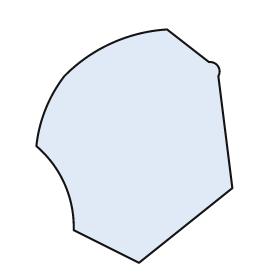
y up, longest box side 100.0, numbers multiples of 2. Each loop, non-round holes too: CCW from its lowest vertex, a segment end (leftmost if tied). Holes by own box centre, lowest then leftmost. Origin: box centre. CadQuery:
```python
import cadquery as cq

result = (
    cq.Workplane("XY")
    .moveTo(2.0, -50.0)
    .lineTo(42.0, -18.0)
    .lineTo(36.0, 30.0)
    .threePointArc((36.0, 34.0), (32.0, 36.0))
    .lineTo(14.0, 50.0)
    .threePointArc((-10.0, 44.0), (-30.0, 30.0))
    .threePointArc((-38.0, 16.0), (-42.0, 0.0))
    .threePointArc((-30.0, -16.0), (-26.0, -36.0))
    .close()
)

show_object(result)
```